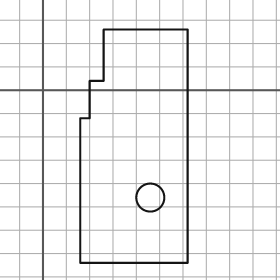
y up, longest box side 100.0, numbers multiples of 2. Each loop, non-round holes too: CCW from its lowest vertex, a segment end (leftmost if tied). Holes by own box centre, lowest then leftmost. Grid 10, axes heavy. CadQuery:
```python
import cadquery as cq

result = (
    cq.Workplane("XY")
    .moveTo(16.0, -74.0)
    .lineTo(62.0, -74.0)
    .lineTo(62.0, 26.0)
    .lineTo(26.0, 26.0)
    .lineTo(26.0, 4.0)
    .lineTo(20.0, 4.0)
    .lineTo(20.0, -12.0)
    .lineTo(16.0, -12.0)
    .close()
    .moveTo(46.0, -46.0)
    .circle(6.0)
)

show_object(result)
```